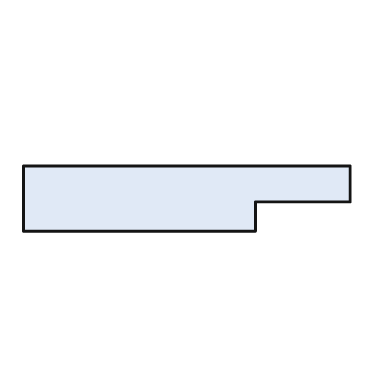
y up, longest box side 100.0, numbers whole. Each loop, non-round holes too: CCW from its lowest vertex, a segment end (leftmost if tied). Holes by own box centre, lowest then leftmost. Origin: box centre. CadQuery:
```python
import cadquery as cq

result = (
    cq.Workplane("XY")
    .moveTo(-50.0, -10.0)
    .lineTo(21.0, -10.0)
    .lineTo(21.0, -1.0)
    .lineTo(50.0, -1.0)
    .lineTo(50.0, 10.0)
    .lineTo(-50.0, 10.0)
    .close()
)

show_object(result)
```